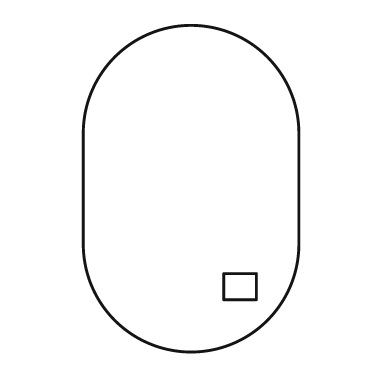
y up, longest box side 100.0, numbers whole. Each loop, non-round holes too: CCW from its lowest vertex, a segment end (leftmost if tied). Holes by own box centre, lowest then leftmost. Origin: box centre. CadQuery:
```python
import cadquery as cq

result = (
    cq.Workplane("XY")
    .moveTo(-33.0, -17.0)
    .threePointArc((0.0, -50.0), (33.0, -17.0))
    .lineTo(33.0, 17.0)
    .threePointArc((0.0, 50.0), (-33.0, 17.0))
    .close()
    .moveTo(10.0, -34.0)
    .lineTo(20.0, -34.0)
    .lineTo(20.0, -26.0)
    .lineTo(10.0, -26.0)
    .close()
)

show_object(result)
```